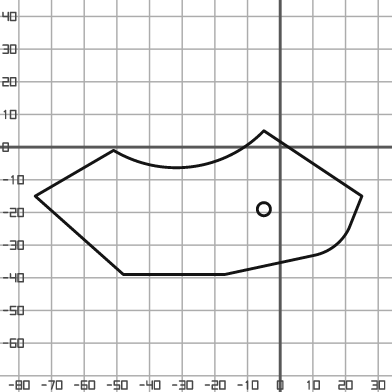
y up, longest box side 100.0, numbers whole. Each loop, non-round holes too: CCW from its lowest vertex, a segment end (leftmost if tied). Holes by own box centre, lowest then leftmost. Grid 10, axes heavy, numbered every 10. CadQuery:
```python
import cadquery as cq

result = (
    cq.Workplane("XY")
    .moveTo(-48.0, -39.0)
    .lineTo(-17.0, -39.0)
    .lineTo(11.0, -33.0)
    .threePointArc((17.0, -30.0), (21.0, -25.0))
    .lineTo(25.0, -15.0)
    .lineTo(-5.0, 5.0)
    .threePointArc((-27.0, -6.0), (-51.0, -1.0))
    .lineTo(-75.0, -15.0)
    .close()
    .moveTo(-5.0, -19.0)
    .circle(2.0)
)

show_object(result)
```